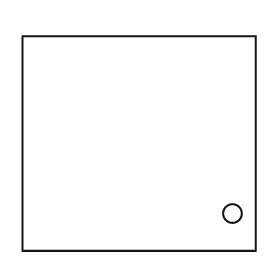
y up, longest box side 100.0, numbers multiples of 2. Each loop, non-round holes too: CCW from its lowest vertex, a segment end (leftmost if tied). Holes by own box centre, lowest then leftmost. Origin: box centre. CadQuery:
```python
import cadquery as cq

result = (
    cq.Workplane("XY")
    .moveTo(-50.0, -46.0)
    .lineTo(50.0, -46.0)
    .lineTo(50.0, 46.0)
    .lineTo(-50.0, 46.0)
    .close()
    .moveTo(40.0, -30.0)
    .circle(4.0)
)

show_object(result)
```